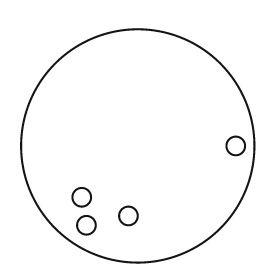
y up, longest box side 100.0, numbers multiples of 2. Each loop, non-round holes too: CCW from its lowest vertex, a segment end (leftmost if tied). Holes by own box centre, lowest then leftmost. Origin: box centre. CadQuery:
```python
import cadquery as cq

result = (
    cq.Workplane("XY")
    .moveTo(0.0, 0.0)
    .circle(50.0)
    .moveTo(-22.0, -34.0)
    .circle(4.0)
    .moveTo(-4.0, -30.0)
    .circle(4.0)
    .moveTo(-24.0, -22.0)
    .circle(4.0)
    .moveTo(42.0, 0.0)
    .circle(4.0)
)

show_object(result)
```